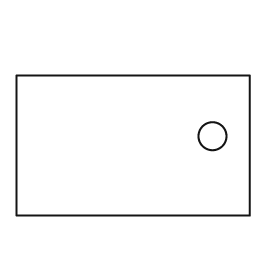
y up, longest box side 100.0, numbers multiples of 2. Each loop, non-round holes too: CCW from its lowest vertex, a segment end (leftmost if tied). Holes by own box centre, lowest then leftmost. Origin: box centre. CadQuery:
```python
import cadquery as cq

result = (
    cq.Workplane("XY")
    .moveTo(-50.0, -30.0)
    .lineTo(50.0, -30.0)
    .lineTo(50.0, 30.0)
    .lineTo(-50.0, 30.0)
    .close()
    .moveTo(34.0, 4.0)
    .circle(6.0)
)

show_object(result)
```